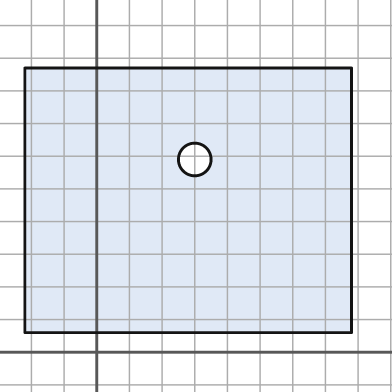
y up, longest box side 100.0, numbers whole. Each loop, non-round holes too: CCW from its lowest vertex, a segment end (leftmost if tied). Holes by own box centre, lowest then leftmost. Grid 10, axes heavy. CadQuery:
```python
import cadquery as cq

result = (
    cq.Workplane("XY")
    .moveTo(-22.0, 6.0)
    .lineTo(78.0, 6.0)
    .lineTo(78.0, 87.0)
    .lineTo(-22.0, 87.0)
    .close()
    .moveTo(30.0, 59.0)
    .circle(5.0)
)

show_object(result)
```